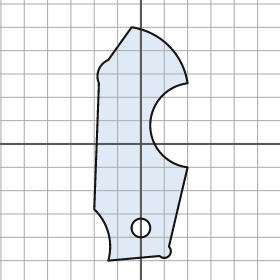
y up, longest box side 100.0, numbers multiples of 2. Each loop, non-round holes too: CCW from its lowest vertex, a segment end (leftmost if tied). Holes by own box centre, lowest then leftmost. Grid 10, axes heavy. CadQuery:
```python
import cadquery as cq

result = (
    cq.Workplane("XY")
    .moveTo(-14.0, -50.0)
    .lineTo(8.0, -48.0)
    .threePointArc((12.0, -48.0), (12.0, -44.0))
    .lineTo(20.0, -10.0)
    .threePointArc((4.0, 8.0), (20.0, 26.0))
    .threePointArc((12.0, 42.0), (-4.0, 50.0))
    .lineTo(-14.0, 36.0)
    .threePointArc((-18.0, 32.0), (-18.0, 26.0))
    .lineTo(-20.0, -28.0)
    .threePointArc((-14.0, -38.0), (-14.0, -50.0))
    .close()
    .moveTo(0.0, -36.0)
    .circle(4.0)
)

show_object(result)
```